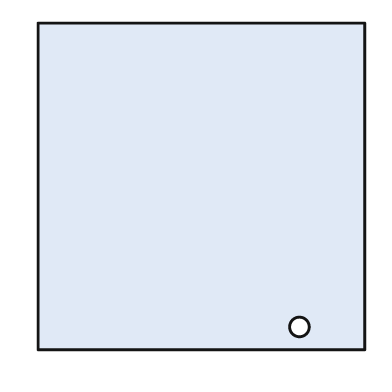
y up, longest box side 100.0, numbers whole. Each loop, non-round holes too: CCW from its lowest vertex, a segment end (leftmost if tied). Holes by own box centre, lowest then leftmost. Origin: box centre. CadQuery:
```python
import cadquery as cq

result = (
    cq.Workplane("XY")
    .moveTo(-50.0, -50.0)
    .lineTo(50.0, -50.0)
    .lineTo(50.0, 50.0)
    .lineTo(-50.0, 50.0)
    .close()
    .moveTo(30.0, -43.0)
    .circle(3.0)
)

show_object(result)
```